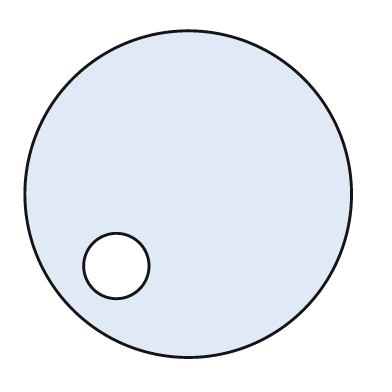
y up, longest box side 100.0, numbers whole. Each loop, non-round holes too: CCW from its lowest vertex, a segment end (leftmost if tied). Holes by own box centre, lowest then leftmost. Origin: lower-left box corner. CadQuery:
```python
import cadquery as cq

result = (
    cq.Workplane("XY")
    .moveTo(50.0, 50.0)
    .circle(50.0)
    .moveTo(28.0, 28.0)
    .circle(10.0)
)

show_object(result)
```